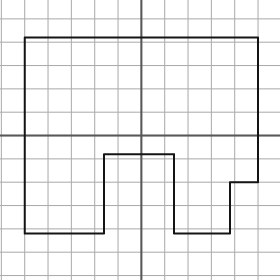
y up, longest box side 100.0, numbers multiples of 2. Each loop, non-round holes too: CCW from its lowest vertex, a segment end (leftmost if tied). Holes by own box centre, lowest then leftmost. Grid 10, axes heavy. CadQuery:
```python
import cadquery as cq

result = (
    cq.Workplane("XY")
    .moveTo(-50.0, -42.0)
    .lineTo(-16.0, -42.0)
    .lineTo(-16.0, -8.0)
    .lineTo(14.0, -8.0)
    .lineTo(14.0, -42.0)
    .lineTo(38.0, -42.0)
    .lineTo(38.0, -20.0)
    .lineTo(50.0, -20.0)
    .lineTo(50.0, 42.0)
    .lineTo(-50.0, 42.0)
    .close()
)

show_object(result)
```